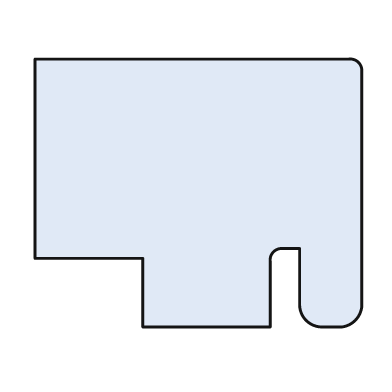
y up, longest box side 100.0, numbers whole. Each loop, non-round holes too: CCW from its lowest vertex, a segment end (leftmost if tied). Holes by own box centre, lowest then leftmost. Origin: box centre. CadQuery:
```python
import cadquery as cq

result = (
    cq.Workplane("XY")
    .moveTo(-17.0, -41.0)
    .lineTo(22.0, -41.0)
    .lineTo(22.0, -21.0)
    .threePointArc((23.0, -18.0), (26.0, -17.0))
    .lineTo(31.0, -17.0)
    .lineTo(31.0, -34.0)
    .threePointArc((33.0, -39.0), (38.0, -41.0))
    .lineTo(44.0, -41.0)
    .threePointArc((48.0, -39.0), (50.0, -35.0))
    .lineTo(50.0, 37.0)
    .threePointArc((49.0, 40.0), (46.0, 41.0))
    .lineTo(-50.0, 41.0)
    .lineTo(-50.0, -20.0)
    .lineTo(-17.0, -20.0)
    .close()
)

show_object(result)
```